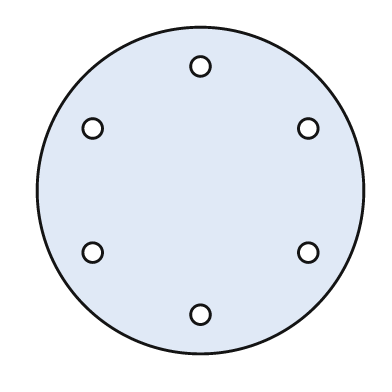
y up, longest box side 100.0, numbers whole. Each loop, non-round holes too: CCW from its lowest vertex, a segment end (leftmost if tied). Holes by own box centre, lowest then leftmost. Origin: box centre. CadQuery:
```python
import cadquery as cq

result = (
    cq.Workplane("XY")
    .moveTo(0.0, 0.0)
    .circle(50.0)
    .moveTo(0.0, -38.0)
    .circle(3.0)
    .moveTo(-33.0, -19.0)
    .circle(3.0)
    .moveTo(33.0, -19.0)
    .circle(3.0)
    .moveTo(-33.0, 19.0)
    .circle(3.0)
    .moveTo(33.0, 19.0)
    .circle(3.0)
    .moveTo(0.0, 38.0)
    .circle(3.0)
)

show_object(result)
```